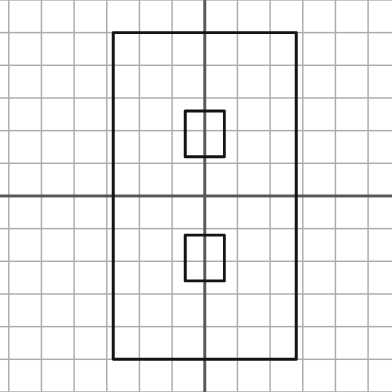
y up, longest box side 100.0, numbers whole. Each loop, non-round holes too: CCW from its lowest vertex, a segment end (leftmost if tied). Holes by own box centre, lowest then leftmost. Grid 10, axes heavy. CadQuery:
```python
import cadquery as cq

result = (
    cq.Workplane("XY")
    .moveTo(-28.0, -50.0)
    .lineTo(28.0, -50.0)
    .lineTo(28.0, 50.0)
    .lineTo(-28.0, 50.0)
    .close()
    .moveTo(-6.0, -26.0)
    .lineTo(6.0, -26.0)
    .lineTo(6.0, -12.0)
    .lineTo(-6.0, -12.0)
    .close()
    .moveTo(-6.0, 12.0)
    .lineTo(6.0, 12.0)
    .lineTo(6.0, 26.0)
    .lineTo(-6.0, 26.0)
    .close()
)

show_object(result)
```